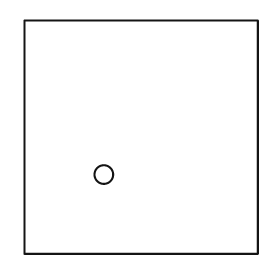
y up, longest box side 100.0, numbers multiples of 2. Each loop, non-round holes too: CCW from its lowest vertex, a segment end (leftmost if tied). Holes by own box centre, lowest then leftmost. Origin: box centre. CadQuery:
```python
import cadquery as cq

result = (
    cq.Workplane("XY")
    .moveTo(-50.0, -50.0)
    .lineTo(50.0, -50.0)
    .lineTo(50.0, 50.0)
    .lineTo(-50.0, 50.0)
    .close()
    .moveTo(-16.0, -16.0)
    .circle(4.0)
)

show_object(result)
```